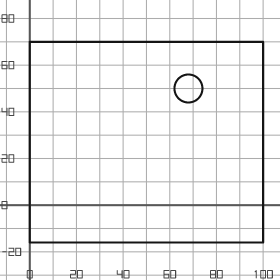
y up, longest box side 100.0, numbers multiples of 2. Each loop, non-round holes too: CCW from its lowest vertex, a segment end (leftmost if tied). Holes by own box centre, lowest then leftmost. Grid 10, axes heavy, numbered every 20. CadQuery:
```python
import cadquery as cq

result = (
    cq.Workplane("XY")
    .moveTo(0.0, -16.0)
    .lineTo(100.0, -16.0)
    .lineTo(100.0, 70.0)
    .lineTo(0.0, 70.0)
    .close()
    .moveTo(68.0, 50.0)
    .circle(6.0)
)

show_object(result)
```